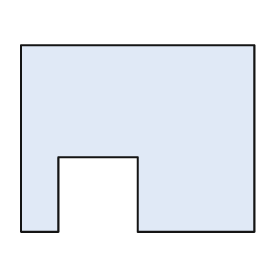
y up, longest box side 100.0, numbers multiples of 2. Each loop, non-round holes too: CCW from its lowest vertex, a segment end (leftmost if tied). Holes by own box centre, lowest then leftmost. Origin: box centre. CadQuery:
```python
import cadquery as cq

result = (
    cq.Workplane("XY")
    .moveTo(-50.0, -40.0)
    .lineTo(-34.0, -40.0)
    .lineTo(-34.0, -8.0)
    .lineTo(0.0, -8.0)
    .lineTo(0.0, -40.0)
    .lineTo(50.0, -40.0)
    .lineTo(50.0, 40.0)
    .lineTo(-50.0, 40.0)
    .close()
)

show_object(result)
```